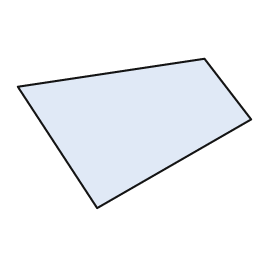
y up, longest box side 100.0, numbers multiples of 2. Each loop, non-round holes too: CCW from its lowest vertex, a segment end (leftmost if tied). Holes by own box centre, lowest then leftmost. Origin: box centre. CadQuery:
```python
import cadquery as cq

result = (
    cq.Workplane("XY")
    .moveTo(-16.0, -32.0)
    .lineTo(50.0, 6.0)
    .lineTo(30.0, 32.0)
    .lineTo(-50.0, 20.0)
    .close()
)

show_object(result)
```